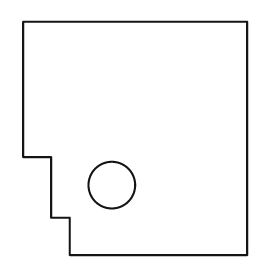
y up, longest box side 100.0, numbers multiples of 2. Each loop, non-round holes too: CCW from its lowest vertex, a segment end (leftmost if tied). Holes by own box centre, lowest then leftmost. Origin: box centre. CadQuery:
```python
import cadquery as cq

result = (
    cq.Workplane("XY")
    .moveTo(-28.0, -50.0)
    .lineTo(48.0, -50.0)
    .lineTo(48.0, 50.0)
    .lineTo(-48.0, 50.0)
    .lineTo(-48.0, -8.0)
    .lineTo(-36.0, -8.0)
    .lineTo(-36.0, -34.0)
    .lineTo(-28.0, -34.0)
    .close()
    .moveTo(-10.0, -20.0)
    .circle(10.0)
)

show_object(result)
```